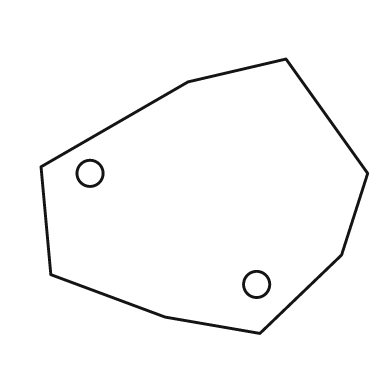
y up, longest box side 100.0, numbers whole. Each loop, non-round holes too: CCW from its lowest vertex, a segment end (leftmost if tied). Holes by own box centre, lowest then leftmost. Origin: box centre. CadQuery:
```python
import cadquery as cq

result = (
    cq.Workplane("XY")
    .moveTo(17.0, -42.0)
    .lineTo(42.0, -18.0)
    .lineTo(50.0, 7.0)
    .lineTo(25.0, 42.0)
    .lineTo(-5.0, 35.0)
    .lineTo(-50.0, 9.0)
    .lineTo(-47.0, -24.0)
    .lineTo(-12.0, -37.0)
    .close()
    .moveTo(16.0, -27.0)
    .circle(4.0)
    .moveTo(-35.0, 7.0)
    .circle(4.0)
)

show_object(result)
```